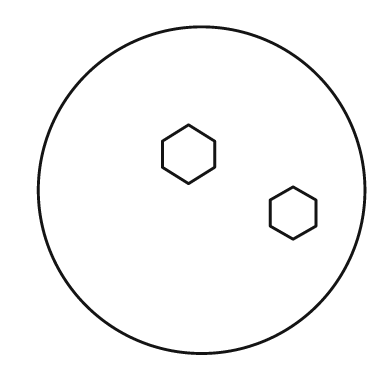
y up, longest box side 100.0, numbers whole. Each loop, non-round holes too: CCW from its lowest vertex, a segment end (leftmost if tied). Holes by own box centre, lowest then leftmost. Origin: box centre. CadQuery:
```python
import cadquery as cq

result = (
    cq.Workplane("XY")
    .moveTo(0.0, 0.0)
    .circle(50.0)
    .moveTo(28.0, -15.0)
    .lineTo(35.0, -11.0)
    .lineTo(35.0, -3.0)
    .lineTo(28.0, 1.0)
    .lineTo(21.0, -3.0)
    .lineTo(21.0, -11.0)
    .close()
    .moveTo(-4.0, 2.0)
    .lineTo(4.0, 7.0)
    .lineTo(4.0, 15.0)
    .lineTo(-4.0, 20.0)
    .lineTo(-12.0, 15.0)
    .lineTo(-12.0, 7.0)
    .close()
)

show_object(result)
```